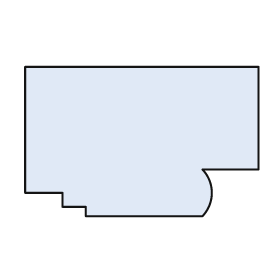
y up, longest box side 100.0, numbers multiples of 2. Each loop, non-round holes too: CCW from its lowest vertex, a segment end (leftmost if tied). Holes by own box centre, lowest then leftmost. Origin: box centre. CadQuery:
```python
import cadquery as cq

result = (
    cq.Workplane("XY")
    .moveTo(-24.0, -32.0)
    .lineTo(26.0, -32.0)
    .threePointArc((30.0, -22.0), (26.0, -12.0))
    .lineTo(50.0, -12.0)
    .lineTo(50.0, 32.0)
    .lineTo(-50.0, 32.0)
    .lineTo(-50.0, -22.0)
    .lineTo(-34.0, -22.0)
    .lineTo(-34.0, -28.0)
    .lineTo(-24.0, -28.0)
    .close()
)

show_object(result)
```